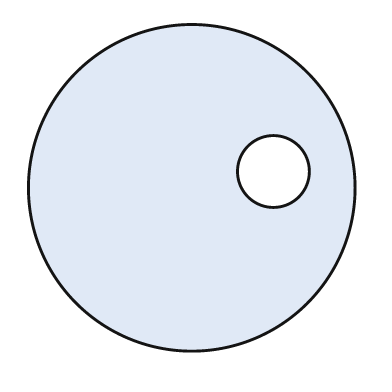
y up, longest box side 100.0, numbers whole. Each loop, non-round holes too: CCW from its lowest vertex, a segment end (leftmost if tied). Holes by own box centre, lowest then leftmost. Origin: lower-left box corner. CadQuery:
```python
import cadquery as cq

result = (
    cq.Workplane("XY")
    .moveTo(50.0, 50.0)
    .circle(50.0)
    .moveTo(75.0, 55.0)
    .circle(11.0)
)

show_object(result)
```